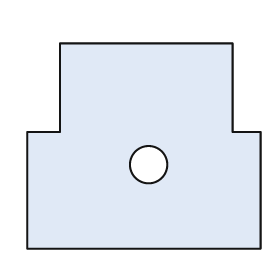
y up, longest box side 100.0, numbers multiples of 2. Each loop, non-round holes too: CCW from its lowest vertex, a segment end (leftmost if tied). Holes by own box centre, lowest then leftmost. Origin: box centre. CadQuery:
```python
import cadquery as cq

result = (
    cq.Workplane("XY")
    .moveTo(-50.0, -44.0)
    .lineTo(50.0, -44.0)
    .lineTo(50.0, 6.0)
    .lineTo(38.0, 6.0)
    .lineTo(38.0, 44.0)
    .lineTo(-36.0, 44.0)
    .lineTo(-36.0, 6.0)
    .lineTo(-50.0, 6.0)
    .close()
    .moveTo(2.0, -8.0)
    .circle(8.0)
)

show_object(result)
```